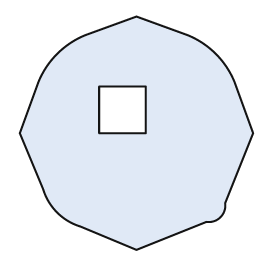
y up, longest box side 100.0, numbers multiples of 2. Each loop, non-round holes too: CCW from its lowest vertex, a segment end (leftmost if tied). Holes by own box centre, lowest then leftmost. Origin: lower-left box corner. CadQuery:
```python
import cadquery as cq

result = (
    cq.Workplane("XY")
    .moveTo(50.0, 0.0)
    .lineTo(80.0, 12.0)
    .threePointArc((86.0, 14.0), (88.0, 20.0))
    .lineTo(100.0, 50.0)
    .lineTo(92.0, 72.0)
    .threePointArc((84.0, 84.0), (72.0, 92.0))
    .lineTo(50.0, 100.0)
    .lineTo(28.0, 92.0)
    .threePointArc((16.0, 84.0), (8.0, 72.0))
    .lineTo(0.0, 50.0)
    .lineTo(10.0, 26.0)
    .threePointArc((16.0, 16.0), (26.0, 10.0))
    .close()
    .moveTo(34.0, 50.0)
    .lineTo(54.0, 50.0)
    .lineTo(54.0, 70.0)
    .lineTo(34.0, 70.0)
    .close()
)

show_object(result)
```